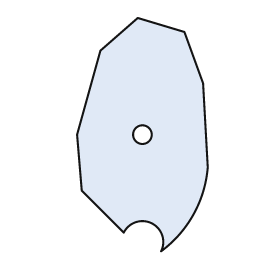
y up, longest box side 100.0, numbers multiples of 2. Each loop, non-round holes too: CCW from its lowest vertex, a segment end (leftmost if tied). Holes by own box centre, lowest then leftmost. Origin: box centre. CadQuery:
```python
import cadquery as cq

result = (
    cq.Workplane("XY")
    .moveTo(8.0, -50.0)
    .threePointArc((22.0, -34.0), (28.0, -14.0))
    .lineTo(26.0, 22.0)
    .lineTo(18.0, 44.0)
    .lineTo(-2.0, 50.0)
    .lineTo(-18.0, 36.0)
    .lineTo(-28.0, 0.0)
    .lineTo(-26.0, -24.0)
    .lineTo(-8.0, -42.0)
    .threePointArc((4.0, -38.0), (8.0, -50.0))
    .close()
    .moveTo(0.0, 0.0)
    .circle(4.0)
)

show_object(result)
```